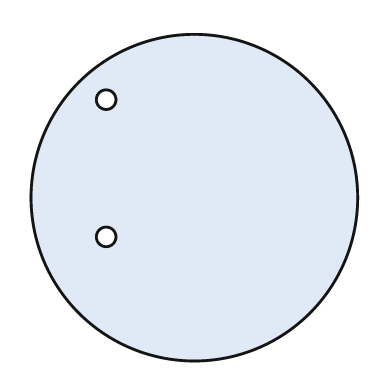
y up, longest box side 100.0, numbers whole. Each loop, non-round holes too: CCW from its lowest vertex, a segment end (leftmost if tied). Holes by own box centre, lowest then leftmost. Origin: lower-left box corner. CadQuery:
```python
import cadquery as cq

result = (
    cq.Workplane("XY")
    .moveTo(50.0, 50.0)
    .circle(50.0)
    .moveTo(23.0, 38.0)
    .circle(3.0)
    .moveTo(23.0, 80.0)
    .circle(3.0)
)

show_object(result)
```